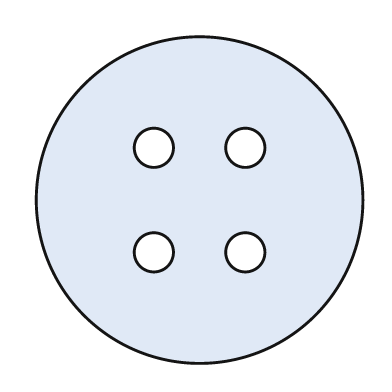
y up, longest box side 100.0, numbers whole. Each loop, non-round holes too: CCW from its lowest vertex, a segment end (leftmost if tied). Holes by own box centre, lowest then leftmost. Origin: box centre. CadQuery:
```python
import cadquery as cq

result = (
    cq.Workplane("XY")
    .moveTo(0.0, 0.0)
    .circle(50.0)
    .moveTo(-14.0, -16.0)
    .circle(6.0)
    .moveTo(14.0, -16.0)
    .circle(6.0)
    .moveTo(-14.0, 16.0)
    .circle(6.0)
    .moveTo(14.0, 16.0)
    .circle(6.0)
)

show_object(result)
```